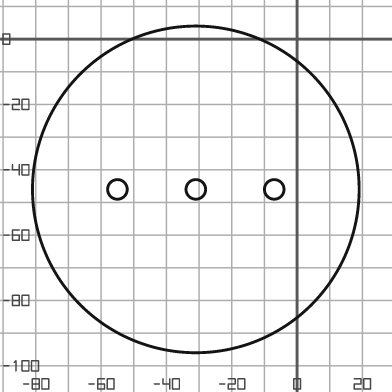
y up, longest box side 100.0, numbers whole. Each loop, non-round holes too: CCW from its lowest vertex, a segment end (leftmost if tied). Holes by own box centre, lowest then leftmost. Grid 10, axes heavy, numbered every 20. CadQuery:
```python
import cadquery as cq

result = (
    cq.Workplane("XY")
    .moveTo(-31.0, -46.0)
    .circle(50.0)
    .moveTo(-55.0, -46.0)
    .circle(3.0)
    .moveTo(-31.0, -46.0)
    .circle(3.0)
    .moveTo(-7.0, -46.0)
    .circle(3.0)
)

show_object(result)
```